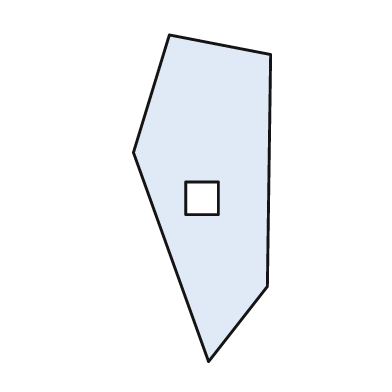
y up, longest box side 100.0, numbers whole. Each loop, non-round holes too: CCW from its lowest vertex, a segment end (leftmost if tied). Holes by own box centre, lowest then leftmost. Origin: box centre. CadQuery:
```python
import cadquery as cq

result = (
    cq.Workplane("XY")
    .moveTo(2.0, -50.0)
    .lineTo(20.0, -27.0)
    .lineTo(21.0, 44.0)
    .lineTo(-10.0, 50.0)
    .lineTo(-21.0, 14.0)
    .close()
    .moveTo(-5.0, -5.0)
    .lineTo(5.0, -5.0)
    .lineTo(5.0, 5.0)
    .lineTo(-5.0, 5.0)
    .close()
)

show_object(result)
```